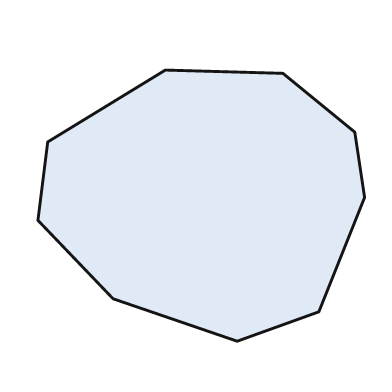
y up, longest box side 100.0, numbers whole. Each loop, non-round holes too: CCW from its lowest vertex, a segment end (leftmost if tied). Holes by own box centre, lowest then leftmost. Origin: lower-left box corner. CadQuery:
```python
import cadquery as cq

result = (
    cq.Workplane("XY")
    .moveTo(61.0, 0.0)
    .lineTo(86.0, 9.0)
    .lineTo(100.0, 44.0)
    .lineTo(97.0, 64.0)
    .lineTo(75.0, 82.0)
    .lineTo(39.0, 83.0)
    .lineTo(3.0, 61.0)
    .lineTo(0.0, 37.0)
    .lineTo(23.0, 13.0)
    .close()
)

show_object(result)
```